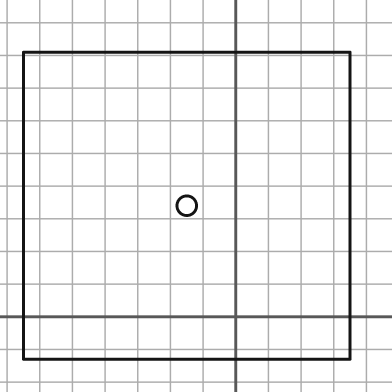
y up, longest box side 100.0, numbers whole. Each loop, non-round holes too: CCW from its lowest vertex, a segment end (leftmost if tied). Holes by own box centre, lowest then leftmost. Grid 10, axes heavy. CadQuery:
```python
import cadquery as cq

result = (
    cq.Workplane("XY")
    .moveTo(-65.0, -13.0)
    .lineTo(35.0, -13.0)
    .lineTo(35.0, 81.0)
    .lineTo(-65.0, 81.0)
    .close()
    .moveTo(-15.0, 34.0)
    .circle(3.0)
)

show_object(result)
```